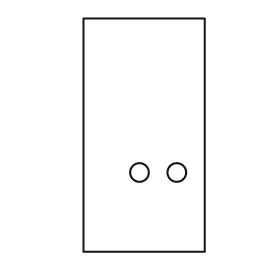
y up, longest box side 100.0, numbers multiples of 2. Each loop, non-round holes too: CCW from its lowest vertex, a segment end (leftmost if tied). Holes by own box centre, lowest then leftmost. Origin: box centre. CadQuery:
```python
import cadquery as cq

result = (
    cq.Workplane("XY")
    .moveTo(-26.0, -50.0)
    .lineTo(26.0, -50.0)
    .lineTo(26.0, 50.0)
    .lineTo(-26.0, 50.0)
    .close()
    .moveTo(-2.0, -16.0)
    .circle(4.0)
    .moveTo(14.0, -16.0)
    .circle(4.0)
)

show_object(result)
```